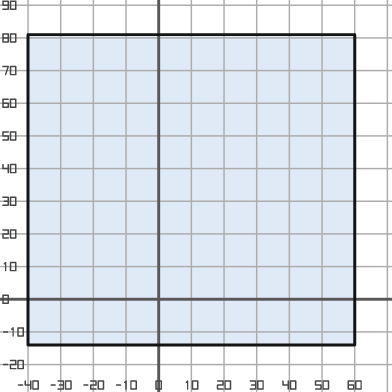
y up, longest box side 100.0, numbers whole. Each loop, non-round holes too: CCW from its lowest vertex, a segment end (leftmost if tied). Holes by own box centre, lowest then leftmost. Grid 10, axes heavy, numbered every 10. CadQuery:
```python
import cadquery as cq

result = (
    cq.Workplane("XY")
    .moveTo(-40.0, -14.0)
    .lineTo(60.0, -14.0)
    .lineTo(60.0, 81.0)
    .lineTo(-40.0, 81.0)
    .close()
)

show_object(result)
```